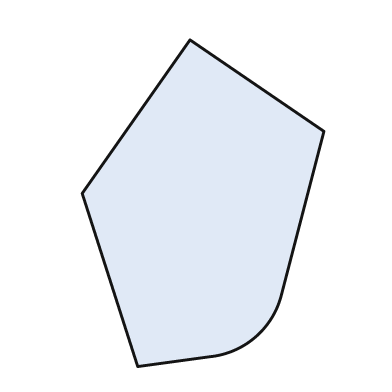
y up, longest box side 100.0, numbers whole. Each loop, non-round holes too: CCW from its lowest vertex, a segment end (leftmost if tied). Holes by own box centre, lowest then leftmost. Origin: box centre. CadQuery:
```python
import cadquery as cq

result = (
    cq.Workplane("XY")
    .moveTo(-20.0, -50.0)
    .lineTo(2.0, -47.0)
    .threePointArc((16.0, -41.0), (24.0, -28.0))
    .lineTo(37.0, 22.0)
    .lineTo(-4.0, 50.0)
    .lineTo(-37.0, 3.0)
    .close()
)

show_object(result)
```